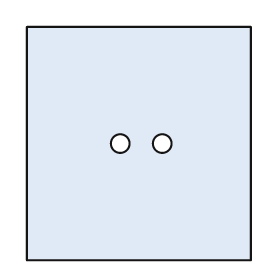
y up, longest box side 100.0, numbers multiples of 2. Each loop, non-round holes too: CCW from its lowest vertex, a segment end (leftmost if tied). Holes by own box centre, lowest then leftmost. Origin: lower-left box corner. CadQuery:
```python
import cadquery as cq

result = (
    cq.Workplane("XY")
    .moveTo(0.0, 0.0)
    .lineTo(96.0, 0.0)
    .lineTo(96.0, 100.0)
    .lineTo(0.0, 100.0)
    .close()
    .moveTo(40.0, 50.0)
    .circle(4.0)
    .moveTo(58.0, 50.0)
    .circle(4.0)
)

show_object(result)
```